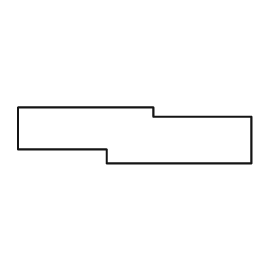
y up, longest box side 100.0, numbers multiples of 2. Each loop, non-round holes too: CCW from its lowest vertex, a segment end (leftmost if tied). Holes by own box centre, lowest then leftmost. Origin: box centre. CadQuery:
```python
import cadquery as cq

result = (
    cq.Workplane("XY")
    .moveTo(-12.0, -12.0)
    .lineTo(50.0, -12.0)
    .lineTo(50.0, 8.0)
    .lineTo(8.0, 8.0)
    .lineTo(8.0, 12.0)
    .lineTo(-50.0, 12.0)
    .lineTo(-50.0, -6.0)
    .lineTo(-12.0, -6.0)
    .close()
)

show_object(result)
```